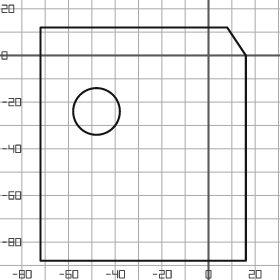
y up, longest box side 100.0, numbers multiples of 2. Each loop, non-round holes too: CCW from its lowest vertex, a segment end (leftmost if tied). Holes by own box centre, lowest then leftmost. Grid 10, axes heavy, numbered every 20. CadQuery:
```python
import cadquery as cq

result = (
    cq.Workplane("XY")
    .moveTo(-72.0, -88.0)
    .lineTo(16.0, -88.0)
    .lineTo(16.0, 0.0)
    .lineTo(8.0, 12.0)
    .lineTo(-72.0, 12.0)
    .close()
    .moveTo(-48.0, -24.0)
    .circle(10.0)
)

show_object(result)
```